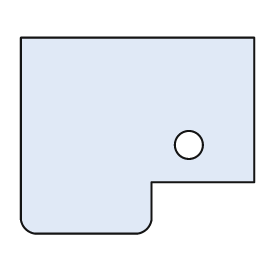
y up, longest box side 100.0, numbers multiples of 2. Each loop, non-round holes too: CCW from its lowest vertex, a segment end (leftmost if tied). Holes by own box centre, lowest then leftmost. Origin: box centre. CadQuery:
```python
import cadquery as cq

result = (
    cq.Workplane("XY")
    .moveTo(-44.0, -42.0)
    .lineTo(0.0, -42.0)
    .threePointArc((4.0, -40.0), (6.0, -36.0))
    .lineTo(6.0, -20.0)
    .lineTo(50.0, -20.0)
    .lineTo(50.0, 42.0)
    .lineTo(-50.0, 42.0)
    .lineTo(-50.0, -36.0)
    .threePointArc((-48.0, -40.0), (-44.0, -42.0))
    .close()
    .moveTo(22.0, -4.0)
    .circle(6.0)
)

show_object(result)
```